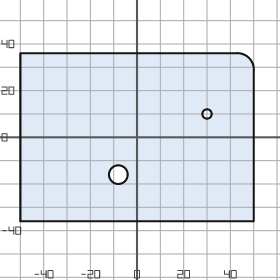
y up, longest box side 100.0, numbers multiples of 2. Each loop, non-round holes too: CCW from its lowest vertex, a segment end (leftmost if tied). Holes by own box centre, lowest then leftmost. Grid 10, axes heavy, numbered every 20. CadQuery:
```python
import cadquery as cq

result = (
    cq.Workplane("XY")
    .moveTo(-50.0, -36.0)
    .lineTo(50.0, -36.0)
    .lineTo(50.0, 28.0)
    .threePointArc((48.0, 34.0), (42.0, 36.0))
    .lineTo(-50.0, 36.0)
    .close()
    .moveTo(-8.0, -16.0)
    .circle(4.0)
    .moveTo(30.0, 10.0)
    .circle(2.0)
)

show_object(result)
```